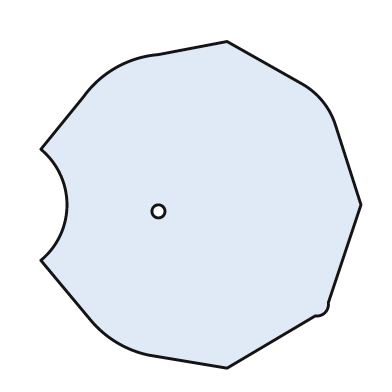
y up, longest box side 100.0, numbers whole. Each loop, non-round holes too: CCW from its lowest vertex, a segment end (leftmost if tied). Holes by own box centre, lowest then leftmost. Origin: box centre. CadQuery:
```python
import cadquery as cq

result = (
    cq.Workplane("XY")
    .moveTo(8.0, -50.0)
    .lineTo(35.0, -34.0)
    .threePointArc((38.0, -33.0), (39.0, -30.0))
    .lineTo(49.0, 0.0)
    .lineTo(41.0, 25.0)
    .threePointArc((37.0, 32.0), (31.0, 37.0))
    .lineTo(8.0, 50.0)
    .lineTo(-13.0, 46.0)
    .threePointArc((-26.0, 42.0), (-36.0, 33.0))
    .lineTo(-49.0, 17.0)
    .threePointArc((-41.0, 0.0), (-49.0, -17.0))
    .lineTo(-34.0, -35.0)
    .threePointArc((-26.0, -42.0), (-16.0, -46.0))
    .close()
    .moveTo(-13.0, -2.0)
    .circle(2.0)
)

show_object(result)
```